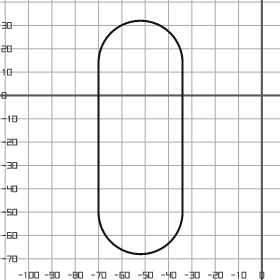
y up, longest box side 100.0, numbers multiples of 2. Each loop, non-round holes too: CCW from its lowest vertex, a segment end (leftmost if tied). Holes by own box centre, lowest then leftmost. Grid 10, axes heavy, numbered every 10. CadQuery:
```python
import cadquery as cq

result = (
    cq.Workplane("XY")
    .moveTo(-70.0, -50.0)
    .threePointArc((-52.0, -68.0), (-34.0, -50.0))
    .lineTo(-34.0, 14.0)
    .threePointArc((-52.0, 32.0), (-70.0, 14.0))
    .close()
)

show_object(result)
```